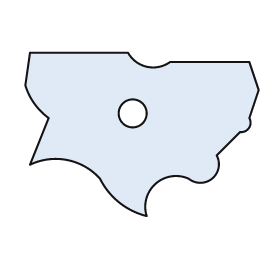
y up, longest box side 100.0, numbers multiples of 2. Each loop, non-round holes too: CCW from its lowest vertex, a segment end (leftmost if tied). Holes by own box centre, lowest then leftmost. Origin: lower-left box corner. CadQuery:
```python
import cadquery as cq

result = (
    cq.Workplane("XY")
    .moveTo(52.0, 0.0)
    .threePointArc((56.0, 14.0), (70.0, 16.0))
    .threePointArc((80.0, 16.0), (82.0, 26.0))
    .lineTo(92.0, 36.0)
    .threePointArc((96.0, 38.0), (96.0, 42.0))
    .lineTo(100.0, 54.0)
    .lineTo(96.0, 66.0)
    .lineTo(62.0, 66.0)
    .threePointArc((52.0, 64.0), (44.0, 70.0))
    .lineTo(2.0, 70.0)
    .lineTo(0.0, 56.0)
    .threePointArc((4.0, 48.0), (10.0, 42.0))
    .lineTo(2.0, 22.0)
    .threePointArc((18.0, 24.0), (32.0, 16.0))
    .threePointArc((40.0, 6.0), (52.0, 0.0))
    .close()
    .moveTo(46.0, 44.0)
    .circle(6.0)
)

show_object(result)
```